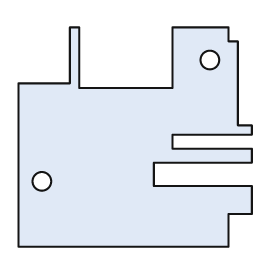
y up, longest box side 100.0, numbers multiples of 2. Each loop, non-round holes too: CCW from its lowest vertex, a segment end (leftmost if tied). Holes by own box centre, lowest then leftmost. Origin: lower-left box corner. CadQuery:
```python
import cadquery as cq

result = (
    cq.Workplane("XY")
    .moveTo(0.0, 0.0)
    .lineTo(90.0, 0.0)
    .lineTo(90.0, 14.0)
    .lineTo(100.0, 14.0)
    .lineTo(100.0, 26.0)
    .lineTo(58.0, 26.0)
    .lineTo(58.0, 36.0)
    .lineTo(100.0, 36.0)
    .lineTo(100.0, 42.0)
    .lineTo(66.0, 42.0)
    .lineTo(66.0, 48.0)
    .lineTo(100.0, 48.0)
    .lineTo(100.0, 52.0)
    .lineTo(94.0, 52.0)
    .lineTo(94.0, 88.0)
    .lineTo(90.0, 88.0)
    .lineTo(90.0, 94.0)
    .lineTo(66.0, 94.0)
    .lineTo(66.0, 68.0)
    .lineTo(26.0, 68.0)
    .lineTo(26.0, 94.0)
    .lineTo(22.0, 94.0)
    .lineTo(22.0, 70.0)
    .lineTo(0.0, 70.0)
    .close()
    .moveTo(10.0, 28.0)
    .circle(4.0)
    .moveTo(82.0, 80.0)
    .circle(4.0)
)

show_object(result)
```